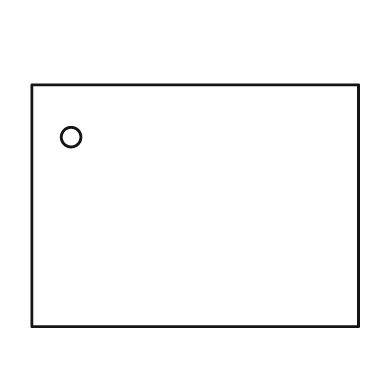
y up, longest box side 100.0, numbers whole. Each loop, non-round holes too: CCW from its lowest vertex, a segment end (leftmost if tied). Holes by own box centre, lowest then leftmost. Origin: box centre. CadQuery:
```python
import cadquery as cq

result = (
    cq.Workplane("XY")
    .moveTo(-50.0, -37.0)
    .lineTo(50.0, -37.0)
    .lineTo(50.0, 37.0)
    .lineTo(-50.0, 37.0)
    .close()
    .moveTo(-38.0, 21.0)
    .circle(3.0)
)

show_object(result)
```